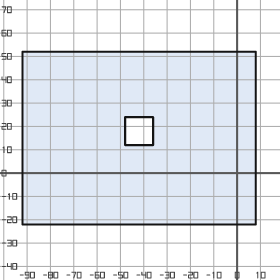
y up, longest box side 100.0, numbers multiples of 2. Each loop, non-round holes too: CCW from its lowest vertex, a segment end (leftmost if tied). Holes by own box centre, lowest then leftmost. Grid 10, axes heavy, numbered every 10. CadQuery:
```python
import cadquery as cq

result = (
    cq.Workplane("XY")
    .moveTo(-92.0, -22.0)
    .lineTo(8.0, -22.0)
    .lineTo(8.0, 52.0)
    .lineTo(-92.0, 52.0)
    .close()
    .moveTo(-48.0, 12.0)
    .lineTo(-36.0, 12.0)
    .lineTo(-36.0, 24.0)
    .lineTo(-48.0, 24.0)
    .close()
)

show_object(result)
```